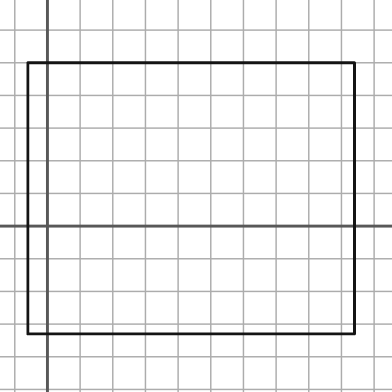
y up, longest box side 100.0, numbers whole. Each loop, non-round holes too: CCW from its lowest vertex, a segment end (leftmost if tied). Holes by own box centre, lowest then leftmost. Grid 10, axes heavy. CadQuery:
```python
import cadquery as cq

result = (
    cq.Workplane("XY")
    .moveTo(-6.0, -33.0)
    .lineTo(94.0, -33.0)
    .lineTo(94.0, 50.0)
    .lineTo(-6.0, 50.0)
    .close()
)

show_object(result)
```